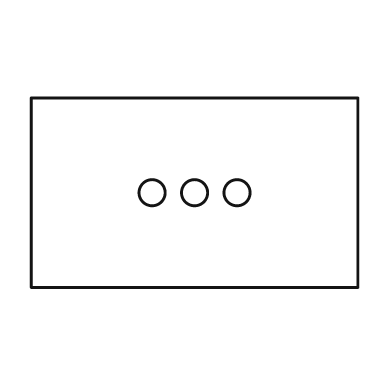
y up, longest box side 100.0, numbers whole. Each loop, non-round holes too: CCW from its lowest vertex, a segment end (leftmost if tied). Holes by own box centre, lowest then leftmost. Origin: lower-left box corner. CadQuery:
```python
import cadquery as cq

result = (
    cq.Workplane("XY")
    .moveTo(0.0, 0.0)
    .lineTo(100.0, 0.0)
    .lineTo(100.0, 58.0)
    .lineTo(0.0, 58.0)
    .close()
    .moveTo(37.0, 29.0)
    .circle(4.0)
    .moveTo(50.0, 29.0)
    .circle(4.0)
    .moveTo(63.0, 29.0)
    .circle(4.0)
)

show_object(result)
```